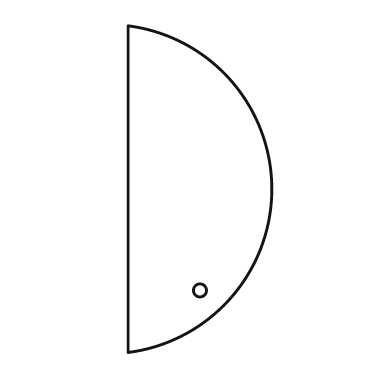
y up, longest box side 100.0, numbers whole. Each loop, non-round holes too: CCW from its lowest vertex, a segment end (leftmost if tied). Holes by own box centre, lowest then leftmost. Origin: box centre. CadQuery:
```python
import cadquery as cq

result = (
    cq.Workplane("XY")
    .moveTo(-22.0, -50.0)
    .threePointArc((22.0, 0.0), (-22.0, 50.0))
    .close()
    .moveTo(0.0, -31.0)
    .circle(2.0)
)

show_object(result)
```